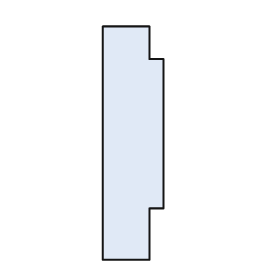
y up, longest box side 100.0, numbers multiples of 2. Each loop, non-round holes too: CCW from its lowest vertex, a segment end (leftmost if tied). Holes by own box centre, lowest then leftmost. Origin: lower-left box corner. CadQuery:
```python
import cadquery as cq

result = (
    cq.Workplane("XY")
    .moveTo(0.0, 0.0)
    .lineTo(20.0, 0.0)
    .lineTo(20.0, 22.0)
    .lineTo(26.0, 22.0)
    .lineTo(26.0, 86.0)
    .lineTo(20.0, 86.0)
    .lineTo(20.0, 100.0)
    .lineTo(0.0, 100.0)
    .close()
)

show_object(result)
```